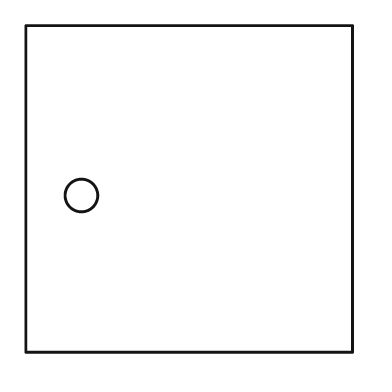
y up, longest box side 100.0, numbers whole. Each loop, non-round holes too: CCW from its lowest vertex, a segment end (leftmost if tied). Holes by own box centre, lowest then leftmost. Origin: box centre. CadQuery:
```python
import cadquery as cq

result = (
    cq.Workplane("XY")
    .moveTo(-50.0, -50.0)
    .lineTo(50.0, -50.0)
    .lineTo(50.0, 50.0)
    .lineTo(-50.0, 50.0)
    .close()
    .moveTo(-33.0, -2.0)
    .circle(5.0)
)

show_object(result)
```